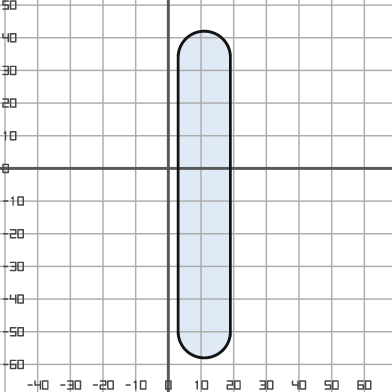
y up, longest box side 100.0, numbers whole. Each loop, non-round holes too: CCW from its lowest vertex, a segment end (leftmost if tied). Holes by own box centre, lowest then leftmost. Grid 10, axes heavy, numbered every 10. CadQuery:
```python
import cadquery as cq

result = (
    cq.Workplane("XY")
    .moveTo(3.0, -50.0)
    .threePointArc((11.0, -58.0), (19.0, -50.0))
    .lineTo(19.0, 34.0)
    .threePointArc((11.0, 42.0), (3.0, 34.0))
    .close()
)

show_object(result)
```